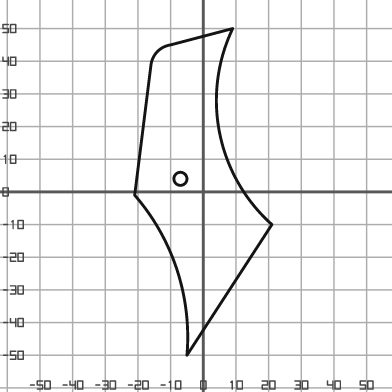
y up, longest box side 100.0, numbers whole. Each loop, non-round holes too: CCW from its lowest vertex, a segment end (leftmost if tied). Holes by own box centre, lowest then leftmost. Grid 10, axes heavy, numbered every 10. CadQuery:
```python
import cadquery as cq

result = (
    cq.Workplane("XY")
    .moveTo(-5.0, -50.0)
    .lineTo(21.0, -10.0)
    .threePointArc((5.0, 18.0), (9.0, 50.0))
    .lineTo(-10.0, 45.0)
    .threePointArc((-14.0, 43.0), (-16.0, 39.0))
    .lineTo(-21.0, -1.0)
    .threePointArc((-8.0, -24.0), (-5.0, -50.0))
    .close()
    .moveTo(-7.0, 4.0)
    .circle(2.0)
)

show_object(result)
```